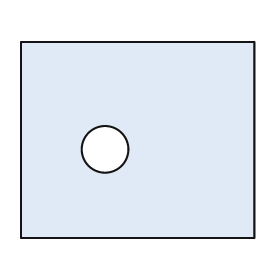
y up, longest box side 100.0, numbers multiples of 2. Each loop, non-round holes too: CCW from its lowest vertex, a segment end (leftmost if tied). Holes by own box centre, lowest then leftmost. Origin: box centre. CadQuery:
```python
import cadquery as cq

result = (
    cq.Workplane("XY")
    .moveTo(-50.0, -42.0)
    .lineTo(50.0, -42.0)
    .lineTo(50.0, 42.0)
    .lineTo(-50.0, 42.0)
    .close()
    .moveTo(-14.0, -4.0)
    .circle(10.0)
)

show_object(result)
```